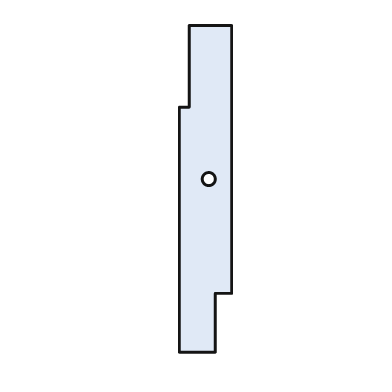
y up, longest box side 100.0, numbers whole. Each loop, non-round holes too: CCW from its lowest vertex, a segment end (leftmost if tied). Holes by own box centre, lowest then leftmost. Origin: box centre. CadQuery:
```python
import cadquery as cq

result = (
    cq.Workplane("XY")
    .moveTo(-8.0, -50.0)
    .lineTo(3.0, -50.0)
    .lineTo(3.0, -32.0)
    .lineTo(8.0, -32.0)
    .lineTo(8.0, 50.0)
    .lineTo(-5.0, 50.0)
    .lineTo(-5.0, 25.0)
    .lineTo(-8.0, 25.0)
    .close()
    .moveTo(1.0, 3.0)
    .circle(2.0)
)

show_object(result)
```